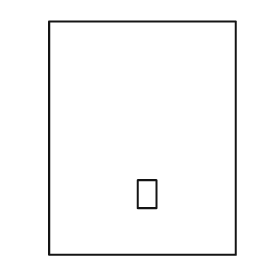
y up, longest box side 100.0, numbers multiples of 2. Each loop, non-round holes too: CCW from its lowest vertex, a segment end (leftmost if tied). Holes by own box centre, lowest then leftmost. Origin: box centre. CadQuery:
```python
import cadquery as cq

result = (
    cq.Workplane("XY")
    .moveTo(-40.0, -50.0)
    .lineTo(40.0, -50.0)
    .lineTo(40.0, 50.0)
    .lineTo(-40.0, 50.0)
    .close()
    .moveTo(-2.0, -30.0)
    .lineTo(6.0, -30.0)
    .lineTo(6.0, -18.0)
    .lineTo(-2.0, -18.0)
    .close()
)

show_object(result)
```